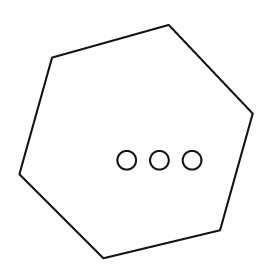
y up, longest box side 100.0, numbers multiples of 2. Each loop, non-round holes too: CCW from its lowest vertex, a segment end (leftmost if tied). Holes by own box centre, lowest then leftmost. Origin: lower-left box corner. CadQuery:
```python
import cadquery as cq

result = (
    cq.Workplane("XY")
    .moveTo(36.0, 0.0)
    .lineTo(86.0, 12.0)
    .lineTo(100.0, 62.0)
    .lineTo(64.0, 100.0)
    .lineTo(14.0, 86.0)
    .lineTo(0.0, 36.0)
    .close()
    .moveTo(46.0, 42.0)
    .circle(4.0)
    .moveTo(60.0, 42.0)
    .circle(4.0)
    .moveTo(74.0, 42.0)
    .circle(4.0)
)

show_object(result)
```